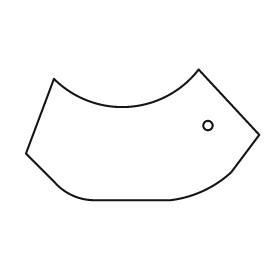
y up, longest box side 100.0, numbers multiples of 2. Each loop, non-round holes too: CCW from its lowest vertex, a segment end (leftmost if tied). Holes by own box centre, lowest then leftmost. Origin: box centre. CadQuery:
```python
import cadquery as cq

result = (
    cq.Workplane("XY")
    .moveTo(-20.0, -28.0)
    .lineTo(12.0, -28.0)
    .threePointArc((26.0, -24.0), (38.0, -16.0))
    .lineTo(50.0, 0.0)
    .lineTo(24.0, 28.0)
    .threePointArc((-6.0, 12.0), (-38.0, 24.0))
    .lineTo(-50.0, -8.0)
    .lineTo(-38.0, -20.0)
    .threePointArc((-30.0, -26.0), (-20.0, -28.0))
    .close()
    .moveTo(28.0, 4.0)
    .circle(2.0)
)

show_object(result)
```